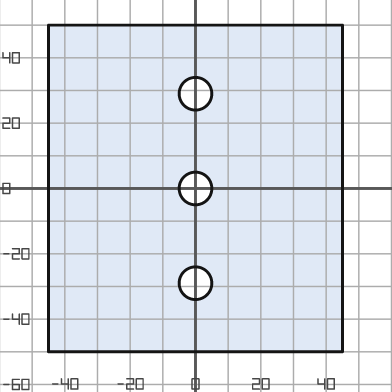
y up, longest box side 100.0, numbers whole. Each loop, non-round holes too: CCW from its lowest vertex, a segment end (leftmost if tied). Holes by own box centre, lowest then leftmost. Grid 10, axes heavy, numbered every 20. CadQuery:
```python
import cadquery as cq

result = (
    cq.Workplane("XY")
    .moveTo(-45.0, -50.0)
    .lineTo(45.0, -50.0)
    .lineTo(45.0, 50.0)
    .lineTo(-45.0, 50.0)
    .close()
    .moveTo(0.0, -29.0)
    .circle(5.0)
    .moveTo(0.0, 0.0)
    .circle(5.0)
    .moveTo(0.0, 29.0)
    .circle(5.0)
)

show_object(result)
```